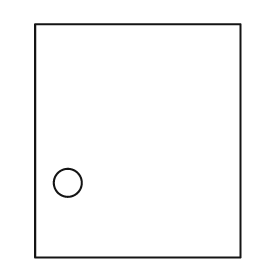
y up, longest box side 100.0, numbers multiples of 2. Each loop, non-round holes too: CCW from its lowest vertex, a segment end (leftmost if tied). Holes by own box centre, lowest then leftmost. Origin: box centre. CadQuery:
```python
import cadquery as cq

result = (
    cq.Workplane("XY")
    .moveTo(-44.0, -50.0)
    .lineTo(44.0, -50.0)
    .lineTo(44.0, 50.0)
    .lineTo(-44.0, 50.0)
    .close()
    .moveTo(-30.0, -18.0)
    .circle(6.0)
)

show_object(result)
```